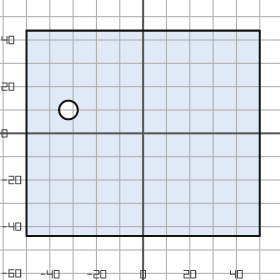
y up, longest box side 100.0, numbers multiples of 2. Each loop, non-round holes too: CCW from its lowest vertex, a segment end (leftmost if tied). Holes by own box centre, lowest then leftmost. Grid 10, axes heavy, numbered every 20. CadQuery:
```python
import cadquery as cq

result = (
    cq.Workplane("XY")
    .moveTo(-50.0, -44.0)
    .lineTo(50.0, -44.0)
    .lineTo(50.0, 44.0)
    .lineTo(-50.0, 44.0)
    .close()
    .moveTo(-32.0, 10.0)
    .circle(4.0)
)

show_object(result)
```